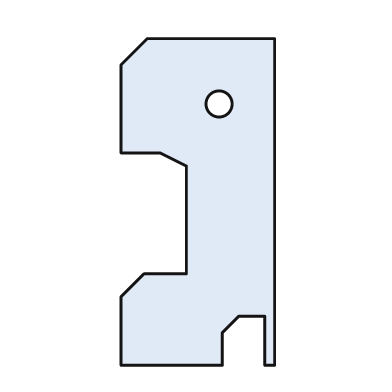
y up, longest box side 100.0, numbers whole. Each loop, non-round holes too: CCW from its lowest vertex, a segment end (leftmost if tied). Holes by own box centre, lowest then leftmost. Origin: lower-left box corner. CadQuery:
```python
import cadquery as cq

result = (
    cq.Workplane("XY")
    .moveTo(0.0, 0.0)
    .lineTo(31.0, 0.0)
    .lineTo(31.0, 10.0)
    .lineTo(36.0, 15.0)
    .lineTo(44.0, 15.0)
    .lineTo(44.0, 0.0)
    .lineTo(47.0, 0.0)
    .lineTo(47.0, 100.0)
    .lineTo(8.0, 100.0)
    .lineTo(0.0, 92.0)
    .lineTo(0.0, 65.0)
    .lineTo(12.0, 65.0)
    .lineTo(20.0, 61.0)
    .lineTo(20.0, 28.0)
    .lineTo(7.0, 28.0)
    .lineTo(0.0, 21.0)
    .close()
    .moveTo(30.0, 80.0)
    .circle(4.0)
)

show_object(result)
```